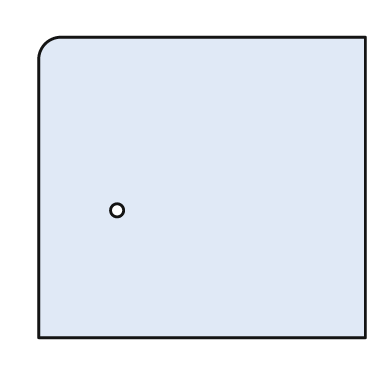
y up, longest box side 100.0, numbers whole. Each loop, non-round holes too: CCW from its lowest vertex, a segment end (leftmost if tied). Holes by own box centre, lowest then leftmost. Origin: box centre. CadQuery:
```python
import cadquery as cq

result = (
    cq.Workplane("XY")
    .moveTo(-50.0, -46.0)
    .lineTo(50.0, -46.0)
    .lineTo(50.0, 46.0)
    .lineTo(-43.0, 46.0)
    .threePointArc((-48.0, 44.0), (-50.0, 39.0))
    .close()
    .moveTo(-26.0, -7.0)
    .circle(2.0)
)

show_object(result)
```